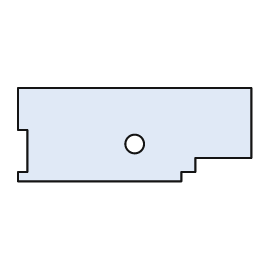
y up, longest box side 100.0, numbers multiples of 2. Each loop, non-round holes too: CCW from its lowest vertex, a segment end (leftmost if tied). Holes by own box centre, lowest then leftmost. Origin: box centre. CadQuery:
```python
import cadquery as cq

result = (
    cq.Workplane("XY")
    .moveTo(-50.0, -20.0)
    .lineTo(20.0, -20.0)
    .lineTo(20.0, -16.0)
    .lineTo(26.0, -16.0)
    .lineTo(26.0, -10.0)
    .lineTo(50.0, -10.0)
    .lineTo(50.0, 20.0)
    .lineTo(-50.0, 20.0)
    .lineTo(-50.0, 2.0)
    .lineTo(-46.0, 2.0)
    .lineTo(-46.0, -16.0)
    .lineTo(-50.0, -16.0)
    .close()
    .moveTo(0.0, -4.0)
    .circle(4.0)
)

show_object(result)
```